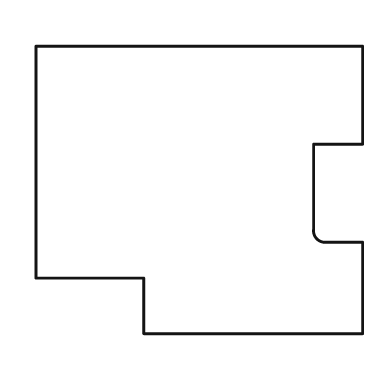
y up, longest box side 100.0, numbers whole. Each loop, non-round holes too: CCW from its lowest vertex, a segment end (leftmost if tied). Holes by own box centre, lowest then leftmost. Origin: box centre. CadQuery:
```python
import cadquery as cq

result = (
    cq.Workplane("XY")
    .moveTo(-17.0, -44.0)
    .lineTo(50.0, -44.0)
    .lineTo(50.0, -16.0)
    .lineTo(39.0, -16.0)
    .threePointArc((36.0, -15.0), (35.0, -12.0))
    .lineTo(35.0, 14.0)
    .lineTo(50.0, 14.0)
    .lineTo(50.0, 44.0)
    .lineTo(-50.0, 44.0)
    .lineTo(-50.0, -27.0)
    .lineTo(-17.0, -27.0)
    .close()
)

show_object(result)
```